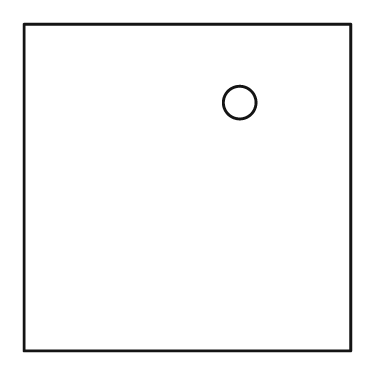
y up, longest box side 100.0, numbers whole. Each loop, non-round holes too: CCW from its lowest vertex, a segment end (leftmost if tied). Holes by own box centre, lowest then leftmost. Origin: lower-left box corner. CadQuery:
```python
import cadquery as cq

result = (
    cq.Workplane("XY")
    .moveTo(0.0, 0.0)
    .lineTo(100.0, 0.0)
    .lineTo(100.0, 100.0)
    .lineTo(0.0, 100.0)
    .close()
    .moveTo(66.0, 76.0)
    .circle(5.0)
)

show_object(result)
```